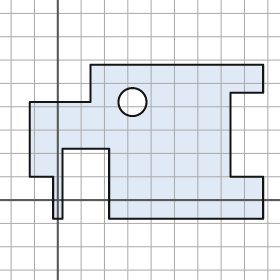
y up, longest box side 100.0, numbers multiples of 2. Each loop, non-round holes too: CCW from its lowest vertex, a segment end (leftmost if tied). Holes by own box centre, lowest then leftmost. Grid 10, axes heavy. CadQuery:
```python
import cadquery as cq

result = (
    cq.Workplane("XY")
    .moveTo(-2.0, -8.0)
    .lineTo(2.0, -8.0)
    .lineTo(2.0, 22.0)
    .lineTo(22.0, 22.0)
    .lineTo(22.0, -8.0)
    .lineTo(88.0, -8.0)
    .lineTo(88.0, 10.0)
    .lineTo(74.0, 10.0)
    .lineTo(74.0, 46.0)
    .lineTo(88.0, 46.0)
    .lineTo(88.0, 58.0)
    .lineTo(14.0, 58.0)
    .lineTo(14.0, 42.0)
    .lineTo(-12.0, 42.0)
    .lineTo(-12.0, 10.0)
    .lineTo(-2.0, 10.0)
    .close()
    .moveTo(32.0, 42.0)
    .circle(6.0)
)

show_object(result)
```